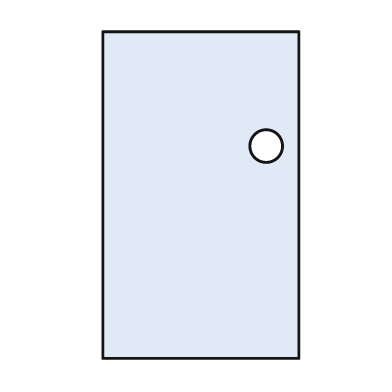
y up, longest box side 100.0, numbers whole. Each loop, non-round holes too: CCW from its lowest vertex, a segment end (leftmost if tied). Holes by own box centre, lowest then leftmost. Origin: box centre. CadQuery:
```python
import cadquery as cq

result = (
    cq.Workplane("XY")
    .moveTo(-30.0, -50.0)
    .lineTo(30.0, -50.0)
    .lineTo(30.0, 50.0)
    .lineTo(-30.0, 50.0)
    .close()
    .moveTo(20.0, 15.0)
    .circle(5.0)
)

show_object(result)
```